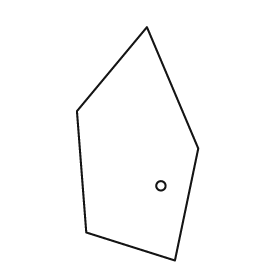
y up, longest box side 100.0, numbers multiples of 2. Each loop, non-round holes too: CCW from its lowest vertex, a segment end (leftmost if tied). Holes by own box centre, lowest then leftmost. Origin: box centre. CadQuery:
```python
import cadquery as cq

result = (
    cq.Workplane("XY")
    .moveTo(16.0, -50.0)
    .lineTo(26.0, -2.0)
    .lineTo(4.0, 50.0)
    .lineTo(-26.0, 14.0)
    .lineTo(-22.0, -38.0)
    .close()
    .moveTo(10.0, -18.0)
    .circle(2.0)
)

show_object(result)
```